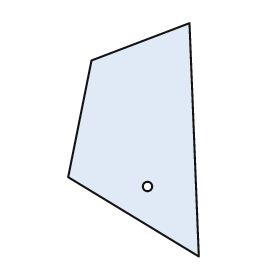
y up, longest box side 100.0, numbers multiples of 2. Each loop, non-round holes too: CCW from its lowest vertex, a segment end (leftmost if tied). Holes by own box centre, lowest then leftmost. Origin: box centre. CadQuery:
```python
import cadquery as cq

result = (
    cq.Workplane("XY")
    .moveTo(28.0, -50.0)
    .lineTo(24.0, 50.0)
    .lineTo(-18.0, 34.0)
    .lineTo(-28.0, -16.0)
    .close()
    .moveTo(6.0, -20.0)
    .circle(2.0)
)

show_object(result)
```